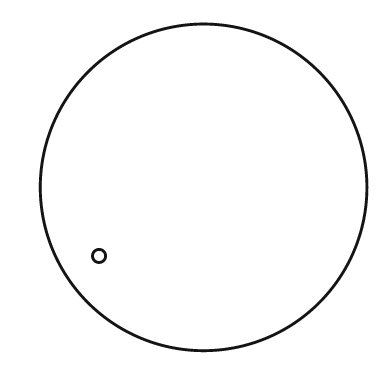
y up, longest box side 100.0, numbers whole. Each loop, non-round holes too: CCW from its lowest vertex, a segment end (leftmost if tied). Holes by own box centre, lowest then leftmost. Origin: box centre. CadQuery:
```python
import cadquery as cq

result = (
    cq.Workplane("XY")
    .moveTo(0.0, 0.0)
    .circle(50.0)
    .moveTo(-32.0, -21.0)
    .circle(2.0)
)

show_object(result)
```